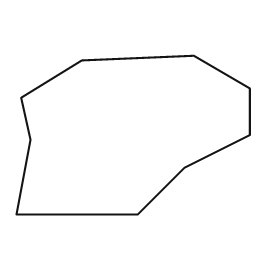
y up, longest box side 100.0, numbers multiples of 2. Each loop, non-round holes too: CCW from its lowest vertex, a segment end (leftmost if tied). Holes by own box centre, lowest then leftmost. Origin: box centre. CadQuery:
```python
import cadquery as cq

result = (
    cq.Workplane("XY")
    .moveTo(-50.0, -34.0)
    .lineTo(2.0, -34.0)
    .lineTo(22.0, -14.0)
    .lineTo(50.0, 0.0)
    .lineTo(50.0, 20.0)
    .lineTo(26.0, 34.0)
    .lineTo(-22.0, 32.0)
    .lineTo(-48.0, 16.0)
    .lineTo(-44.0, -2.0)
    .close()
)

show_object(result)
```